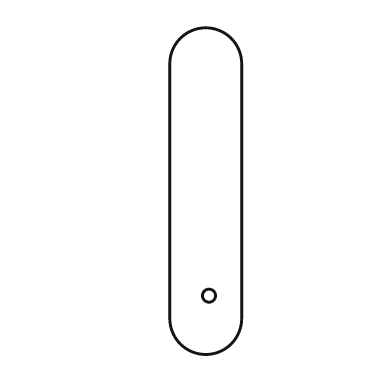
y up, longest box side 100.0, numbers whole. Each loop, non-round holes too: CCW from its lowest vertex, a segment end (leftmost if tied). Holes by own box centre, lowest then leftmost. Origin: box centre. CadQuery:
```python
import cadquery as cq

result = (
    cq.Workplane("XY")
    .moveTo(-11.0, -39.0)
    .threePointArc((0.0, -50.0), (11.0, -39.0))
    .lineTo(11.0, 39.0)
    .threePointArc((0.0, 50.0), (-11.0, 39.0))
    .close()
    .moveTo(1.0, -32.0)
    .circle(2.0)
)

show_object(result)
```